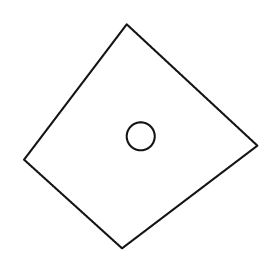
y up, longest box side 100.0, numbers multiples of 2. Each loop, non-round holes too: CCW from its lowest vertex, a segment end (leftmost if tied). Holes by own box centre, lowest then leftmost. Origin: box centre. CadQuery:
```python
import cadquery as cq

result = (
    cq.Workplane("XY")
    .moveTo(-8.0, -48.0)
    .lineTo(50.0, -4.0)
    .lineTo(-6.0, 48.0)
    .lineTo(-50.0, -10.0)
    .close()
    .moveTo(0.0, 0.0)
    .circle(6.0)
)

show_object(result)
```